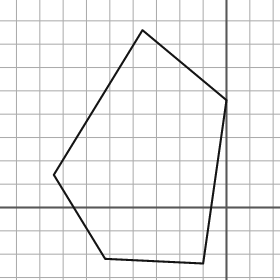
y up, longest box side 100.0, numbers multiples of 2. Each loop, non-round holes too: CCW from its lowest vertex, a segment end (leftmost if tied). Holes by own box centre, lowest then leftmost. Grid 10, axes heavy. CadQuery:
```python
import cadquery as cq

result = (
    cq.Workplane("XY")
    .moveTo(-10.0, -24.0)
    .lineTo(0.0, 46.0)
    .lineTo(-36.0, 76.0)
    .lineTo(-74.0, 14.0)
    .lineTo(-52.0, -22.0)
    .close()
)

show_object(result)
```